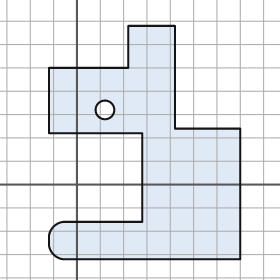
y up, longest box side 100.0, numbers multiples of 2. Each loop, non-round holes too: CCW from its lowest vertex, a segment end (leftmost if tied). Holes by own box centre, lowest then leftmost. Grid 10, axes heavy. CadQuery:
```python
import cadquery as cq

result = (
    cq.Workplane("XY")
    .moveTo(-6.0, -32.0)
    .lineTo(70.0, -32.0)
    .lineTo(70.0, 24.0)
    .lineTo(42.0, 24.0)
    .lineTo(42.0, 68.0)
    .lineTo(22.0, 68.0)
    .lineTo(22.0, 50.0)
    .lineTo(-12.0, 50.0)
    .lineTo(-12.0, 22.0)
    .lineTo(28.0, 22.0)
    .lineTo(28.0, -16.0)
    .lineTo(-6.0, -16.0)
    .threePointArc((-10.0, -18.0), (-12.0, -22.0))
    .lineTo(-12.0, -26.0)
    .threePointArc((-10.0, -30.0), (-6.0, -32.0))
    .close()
    .moveTo(12.0, 32.0)
    .circle(4.0)
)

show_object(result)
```